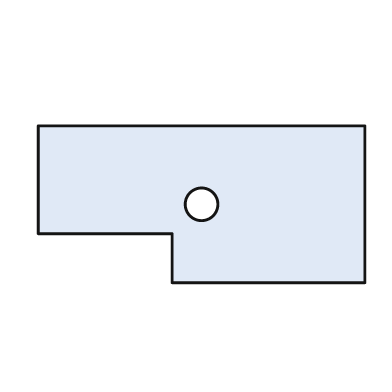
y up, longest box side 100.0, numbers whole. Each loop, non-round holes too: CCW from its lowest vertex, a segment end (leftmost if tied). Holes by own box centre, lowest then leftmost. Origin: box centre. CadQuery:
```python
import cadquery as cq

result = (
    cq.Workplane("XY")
    .moveTo(-9.0, -24.0)
    .lineTo(50.0, -24.0)
    .lineTo(50.0, 24.0)
    .lineTo(-50.0, 24.0)
    .lineTo(-50.0, -9.0)
    .lineTo(-9.0, -9.0)
    .close()
    .moveTo(0.0, 0.0)
    .circle(5.0)
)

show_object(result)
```